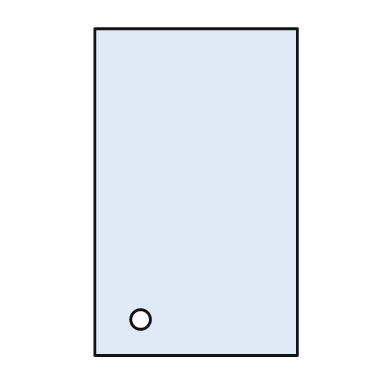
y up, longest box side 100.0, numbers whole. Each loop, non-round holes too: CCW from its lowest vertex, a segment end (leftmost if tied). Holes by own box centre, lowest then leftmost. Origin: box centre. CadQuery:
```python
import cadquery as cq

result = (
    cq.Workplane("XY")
    .moveTo(-31.0, -50.0)
    .lineTo(31.0, -50.0)
    .lineTo(31.0, 50.0)
    .lineTo(-31.0, 50.0)
    .close()
    .moveTo(-17.0, -39.0)
    .circle(3.0)
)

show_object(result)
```